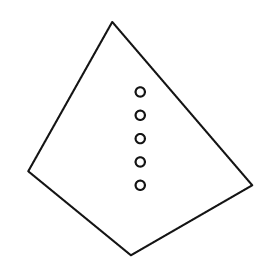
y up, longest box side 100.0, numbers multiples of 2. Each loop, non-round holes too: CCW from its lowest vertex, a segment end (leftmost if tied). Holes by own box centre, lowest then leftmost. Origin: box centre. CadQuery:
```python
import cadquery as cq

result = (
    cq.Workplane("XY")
    .moveTo(-4.0, -50.0)
    .lineTo(48.0, -20.0)
    .lineTo(-12.0, 50.0)
    .lineTo(-48.0, -14.0)
    .close()
    .moveTo(0.0, -20.0)
    .circle(2.0)
    .moveTo(0.0, -10.0)
    .circle(2.0)
    .moveTo(0.0, 0.0)
    .circle(2.0)
    .moveTo(0.0, 10.0)
    .circle(2.0)
    .moveTo(0.0, 20.0)
    .circle(2.0)
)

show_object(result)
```